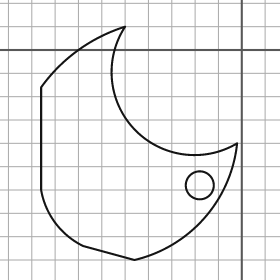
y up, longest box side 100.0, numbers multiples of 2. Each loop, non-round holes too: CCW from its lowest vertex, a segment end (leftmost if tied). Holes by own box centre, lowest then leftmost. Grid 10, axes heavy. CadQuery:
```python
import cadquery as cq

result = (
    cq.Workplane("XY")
    .moveTo(-46.0, -90.0)
    .threePointArc((-16.0, -72.0), (-2.0, -40.0))
    .threePointArc((-46.0, -34.0), (-50.0, 10.0))
    .threePointArc((-70.0, 0.0), (-86.0, -16.0))
    .lineTo(-86.0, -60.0)
    .threePointArc((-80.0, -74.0), (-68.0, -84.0))
    .close()
    .moveTo(-18.0, -58.0)
    .circle(6.0)
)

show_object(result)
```